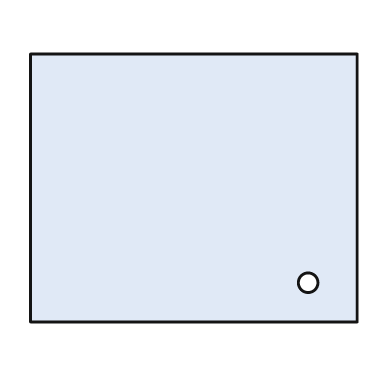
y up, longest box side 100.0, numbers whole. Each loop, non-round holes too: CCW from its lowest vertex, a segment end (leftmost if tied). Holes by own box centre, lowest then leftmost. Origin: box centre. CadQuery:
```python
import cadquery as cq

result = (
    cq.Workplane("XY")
    .moveTo(-50.0, -41.0)
    .lineTo(50.0, -41.0)
    .lineTo(50.0, 41.0)
    .lineTo(-50.0, 41.0)
    .close()
    .moveTo(35.0, -29.0)
    .circle(3.0)
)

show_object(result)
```